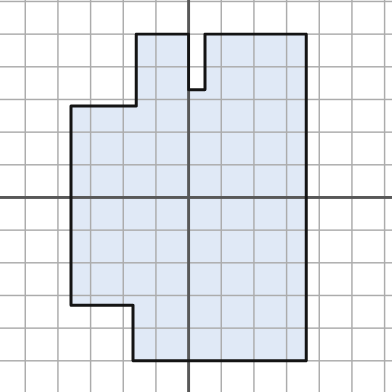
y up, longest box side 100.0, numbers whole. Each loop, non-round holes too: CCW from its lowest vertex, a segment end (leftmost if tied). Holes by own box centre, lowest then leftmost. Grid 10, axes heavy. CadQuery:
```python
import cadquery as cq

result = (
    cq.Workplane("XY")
    .moveTo(-17.0, -50.0)
    .lineTo(36.0, -50.0)
    .lineTo(36.0, 50.0)
    .lineTo(5.0, 50.0)
    .lineTo(5.0, 33.0)
    .lineTo(0.0, 33.0)
    .lineTo(0.0, 50.0)
    .lineTo(-16.0, 50.0)
    .lineTo(-16.0, 28.0)
    .lineTo(-36.0, 28.0)
    .lineTo(-36.0, -33.0)
    .lineTo(-17.0, -33.0)
    .close()
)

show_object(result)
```